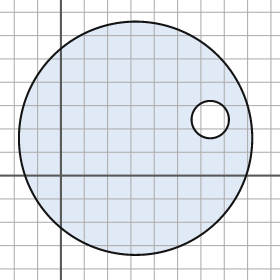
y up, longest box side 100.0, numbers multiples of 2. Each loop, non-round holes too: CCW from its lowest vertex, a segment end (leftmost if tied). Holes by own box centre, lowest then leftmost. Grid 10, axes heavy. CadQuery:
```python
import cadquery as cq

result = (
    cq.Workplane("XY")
    .moveTo(32.0, 16.0)
    .circle(50.0)
    .moveTo(64.0, 24.0)
    .circle(8.0)
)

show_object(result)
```